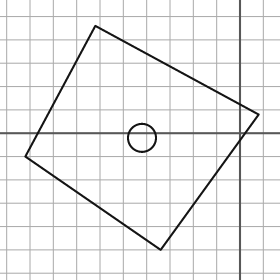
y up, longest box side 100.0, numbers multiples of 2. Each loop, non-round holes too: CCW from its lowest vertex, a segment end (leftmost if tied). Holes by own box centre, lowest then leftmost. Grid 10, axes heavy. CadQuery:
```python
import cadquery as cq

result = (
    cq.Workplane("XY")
    .moveTo(-34.0, -50.0)
    .lineTo(8.0, 8.0)
    .lineTo(-62.0, 46.0)
    .lineTo(-92.0, -10.0)
    .close()
    .moveTo(-42.0, -2.0)
    .circle(6.0)
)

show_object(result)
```